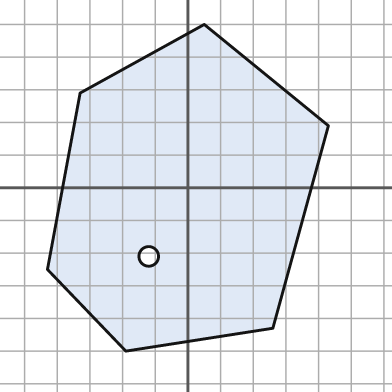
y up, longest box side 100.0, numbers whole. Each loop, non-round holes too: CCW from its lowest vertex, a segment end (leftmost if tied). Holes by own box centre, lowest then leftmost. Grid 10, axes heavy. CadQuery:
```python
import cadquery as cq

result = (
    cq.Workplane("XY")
    .moveTo(-19.0, -50.0)
    .lineTo(26.0, -43.0)
    .lineTo(43.0, 19.0)
    .lineTo(5.0, 50.0)
    .lineTo(-33.0, 29.0)
    .lineTo(-43.0, -25.0)
    .close()
    .moveTo(-12.0, -21.0)
    .circle(3.0)
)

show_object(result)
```